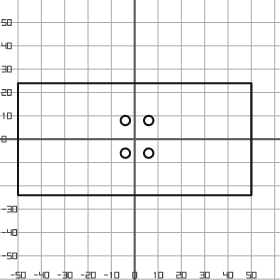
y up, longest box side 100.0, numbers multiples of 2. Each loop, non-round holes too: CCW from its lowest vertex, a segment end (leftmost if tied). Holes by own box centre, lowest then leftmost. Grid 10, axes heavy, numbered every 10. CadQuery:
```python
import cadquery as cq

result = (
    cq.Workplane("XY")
    .moveTo(-50.0, -24.0)
    .lineTo(50.0, -24.0)
    .lineTo(50.0, 24.0)
    .lineTo(-50.0, 24.0)
    .close()
    .moveTo(-4.0, -6.0)
    .circle(2.0)
    .moveTo(6.0, -6.0)
    .circle(2.0)
    .moveTo(-4.0, 8.0)
    .circle(2.0)
    .moveTo(6.0, 8.0)
    .circle(2.0)
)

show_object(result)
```